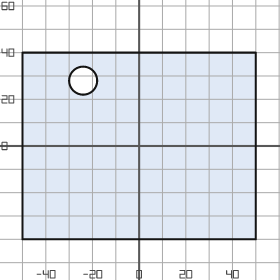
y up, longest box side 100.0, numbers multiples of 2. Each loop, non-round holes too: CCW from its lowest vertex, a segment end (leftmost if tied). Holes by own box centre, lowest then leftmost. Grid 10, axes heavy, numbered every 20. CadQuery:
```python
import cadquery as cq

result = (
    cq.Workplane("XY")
    .moveTo(-50.0, -40.0)
    .lineTo(50.0, -40.0)
    .lineTo(50.0, 40.0)
    .lineTo(-50.0, 40.0)
    .close()
    .moveTo(-24.0, 28.0)
    .circle(6.0)
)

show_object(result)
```